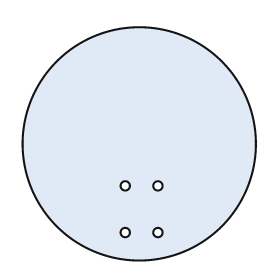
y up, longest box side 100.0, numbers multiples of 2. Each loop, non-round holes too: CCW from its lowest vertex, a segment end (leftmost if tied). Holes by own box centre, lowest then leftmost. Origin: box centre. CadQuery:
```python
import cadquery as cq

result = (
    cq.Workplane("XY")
    .moveTo(0.0, 0.0)
    .circle(50.0)
    .moveTo(-6.0, -38.0)
    .circle(2.0)
    .moveTo(8.0, -38.0)
    .circle(2.0)
    .moveTo(-6.0, -18.0)
    .circle(2.0)
    .moveTo(8.0, -18.0)
    .circle(2.0)
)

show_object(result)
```